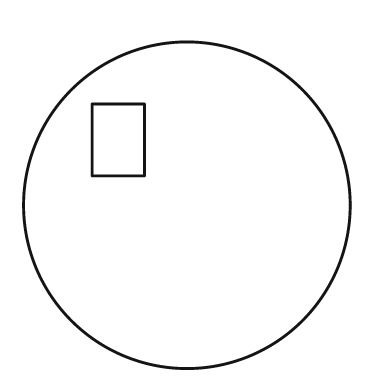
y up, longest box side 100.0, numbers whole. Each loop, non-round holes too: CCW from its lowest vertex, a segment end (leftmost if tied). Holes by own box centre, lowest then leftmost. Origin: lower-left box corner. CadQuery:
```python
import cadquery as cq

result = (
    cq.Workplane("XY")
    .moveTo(50.0, 50.0)
    .circle(50.0)
    .moveTo(21.0, 59.0)
    .lineTo(37.0, 59.0)
    .lineTo(37.0, 81.0)
    .lineTo(21.0, 81.0)
    .close()
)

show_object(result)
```